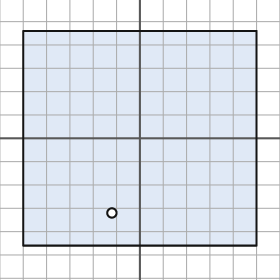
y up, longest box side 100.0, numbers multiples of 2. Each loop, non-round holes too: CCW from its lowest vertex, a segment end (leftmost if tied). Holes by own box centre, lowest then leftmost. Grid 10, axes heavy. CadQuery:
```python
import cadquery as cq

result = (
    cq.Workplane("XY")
    .moveTo(-50.0, -46.0)
    .lineTo(50.0, -46.0)
    .lineTo(50.0, 46.0)
    .lineTo(-50.0, 46.0)
    .close()
    .moveTo(-12.0, -32.0)
    .circle(2.0)
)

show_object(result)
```